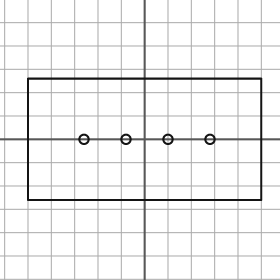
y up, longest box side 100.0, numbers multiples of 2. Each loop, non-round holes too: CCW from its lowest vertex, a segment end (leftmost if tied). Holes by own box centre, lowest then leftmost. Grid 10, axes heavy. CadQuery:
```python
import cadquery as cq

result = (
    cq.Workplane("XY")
    .moveTo(-50.0, -26.0)
    .lineTo(50.0, -26.0)
    .lineTo(50.0, 26.0)
    .lineTo(-50.0, 26.0)
    .close()
    .moveTo(-26.0, 0.0)
    .circle(2.0)
    .moveTo(-8.0, 0.0)
    .circle(2.0)
    .moveTo(10.0, 0.0)
    .circle(2.0)
    .moveTo(28.0, 0.0)
    .circle(2.0)
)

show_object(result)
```